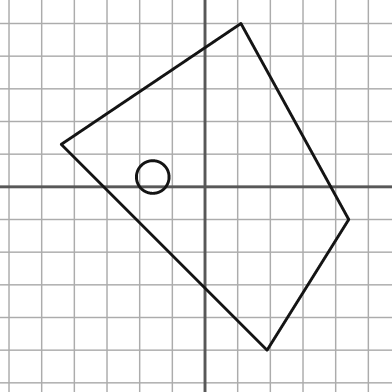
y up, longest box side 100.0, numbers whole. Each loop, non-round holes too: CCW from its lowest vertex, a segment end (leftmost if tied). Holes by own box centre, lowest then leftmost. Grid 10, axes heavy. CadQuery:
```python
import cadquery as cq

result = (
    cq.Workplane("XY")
    .moveTo(19.0, -50.0)
    .lineTo(44.0, -10.0)
    .lineTo(11.0, 50.0)
    .lineTo(-44.0, 13.0)
    .close()
    .moveTo(-16.0, 3.0)
    .circle(5.0)
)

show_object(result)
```